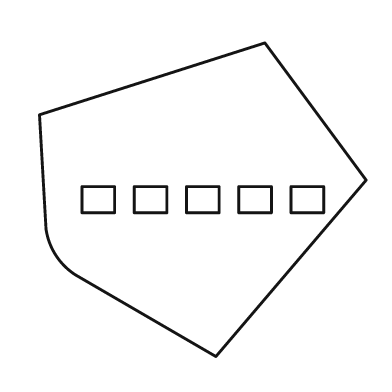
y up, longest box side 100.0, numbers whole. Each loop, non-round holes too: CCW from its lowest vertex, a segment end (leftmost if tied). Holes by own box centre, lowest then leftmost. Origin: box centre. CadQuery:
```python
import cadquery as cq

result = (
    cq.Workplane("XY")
    .moveTo(4.0, -48.0)
    .lineTo(50.0, 6.0)
    .lineTo(19.0, 48.0)
    .lineTo(-50.0, 26.0)
    .lineTo(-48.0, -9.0)
    .threePointArc((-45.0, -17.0), (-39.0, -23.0))
    .close()
    .moveTo(-37.0, -4.0)
    .lineTo(-27.0, -4.0)
    .lineTo(-27.0, 4.0)
    .lineTo(-37.0, 4.0)
    .close()
    .moveTo(-21.0, -4.0)
    .lineTo(-11.0, -4.0)
    .lineTo(-11.0, 4.0)
    .lineTo(-21.0, 4.0)
    .close()
    .moveTo(-5.0, -4.0)
    .lineTo(5.0, -4.0)
    .lineTo(5.0, 4.0)
    .lineTo(-5.0, 4.0)
    .close()
    .moveTo(11.0, -4.0)
    .lineTo(21.0, -4.0)
    .lineTo(21.0, 4.0)
    .lineTo(11.0, 4.0)
    .close()
    .moveTo(27.0, -4.0)
    .lineTo(37.0, -4.0)
    .lineTo(37.0, 4.0)
    .lineTo(27.0, 4.0)
    .close()
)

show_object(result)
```